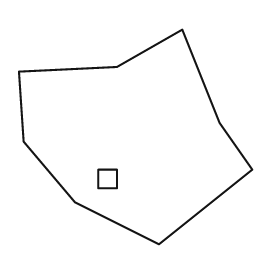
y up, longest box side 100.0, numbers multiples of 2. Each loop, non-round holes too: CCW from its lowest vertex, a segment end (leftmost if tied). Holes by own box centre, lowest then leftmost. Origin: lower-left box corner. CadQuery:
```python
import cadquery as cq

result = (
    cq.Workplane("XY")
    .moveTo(60.0, 0.0)
    .lineTo(100.0, 32.0)
    .lineTo(86.0, 52.0)
    .lineTo(70.0, 92.0)
    .lineTo(42.0, 76.0)
    .lineTo(0.0, 74.0)
    .lineTo(2.0, 44.0)
    .lineTo(24.0, 18.0)
    .close()
    .moveTo(34.0, 24.0)
    .lineTo(42.0, 24.0)
    .lineTo(42.0, 32.0)
    .lineTo(34.0, 32.0)
    .close()
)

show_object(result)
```